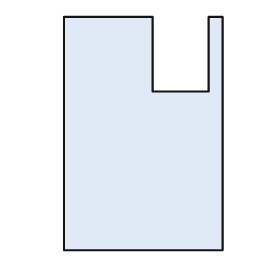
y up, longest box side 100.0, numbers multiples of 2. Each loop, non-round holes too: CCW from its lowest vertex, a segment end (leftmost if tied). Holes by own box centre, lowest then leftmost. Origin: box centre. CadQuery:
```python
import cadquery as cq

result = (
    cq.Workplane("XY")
    .moveTo(-34.0, -50.0)
    .lineTo(34.0, -50.0)
    .lineTo(34.0, 50.0)
    .lineTo(28.0, 50.0)
    .lineTo(28.0, 18.0)
    .lineTo(4.0, 18.0)
    .lineTo(4.0, 50.0)
    .lineTo(-34.0, 50.0)
    .close()
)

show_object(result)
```